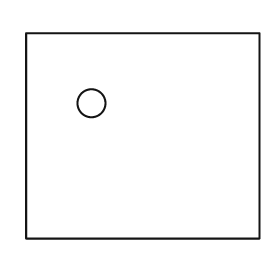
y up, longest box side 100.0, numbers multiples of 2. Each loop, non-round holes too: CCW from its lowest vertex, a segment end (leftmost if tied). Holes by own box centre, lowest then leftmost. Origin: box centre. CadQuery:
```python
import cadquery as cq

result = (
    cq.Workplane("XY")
    .moveTo(-50.0, -44.0)
    .lineTo(50.0, -44.0)
    .lineTo(50.0, 44.0)
    .lineTo(-50.0, 44.0)
    .close()
    .moveTo(-22.0, 14.0)
    .circle(6.0)
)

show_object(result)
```